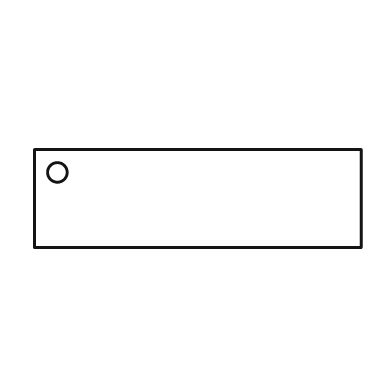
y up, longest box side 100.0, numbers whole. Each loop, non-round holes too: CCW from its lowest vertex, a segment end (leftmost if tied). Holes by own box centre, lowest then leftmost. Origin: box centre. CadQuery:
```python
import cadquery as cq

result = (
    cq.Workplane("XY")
    .moveTo(-50.0, -15.0)
    .lineTo(50.0, -15.0)
    .lineTo(50.0, 15.0)
    .lineTo(-50.0, 15.0)
    .close()
    .moveTo(-43.0, 8.0)
    .circle(3.0)
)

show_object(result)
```